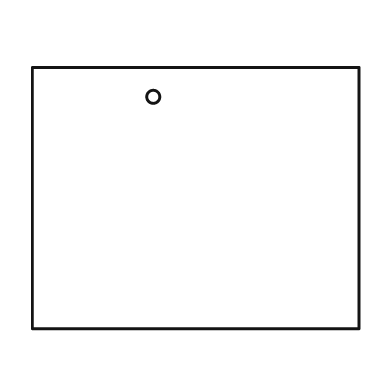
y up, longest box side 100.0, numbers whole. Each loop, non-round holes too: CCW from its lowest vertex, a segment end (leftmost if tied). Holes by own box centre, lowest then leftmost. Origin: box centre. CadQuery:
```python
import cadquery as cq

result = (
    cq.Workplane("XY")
    .moveTo(-50.0, -40.0)
    .lineTo(50.0, -40.0)
    .lineTo(50.0, 40.0)
    .lineTo(-50.0, 40.0)
    .close()
    .moveTo(-13.0, 31.0)
    .circle(2.0)
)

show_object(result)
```